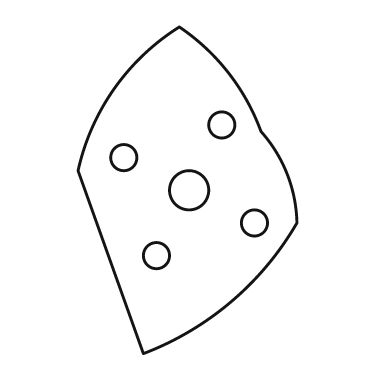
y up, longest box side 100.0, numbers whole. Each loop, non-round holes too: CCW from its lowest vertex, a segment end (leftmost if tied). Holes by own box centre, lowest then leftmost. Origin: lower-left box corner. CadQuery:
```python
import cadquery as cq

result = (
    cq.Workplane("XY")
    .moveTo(20.0, 0.0)
    .threePointArc((47.0, 16.0), (67.0, 40.0))
    .threePointArc((64.0, 55.0), (56.0, 68.0))
    .threePointArc((46.0, 86.0), (31.0, 100.0))
    .threePointArc((11.0, 81.0), (0.0, 56.0))
    .close()
    .moveTo(24.0, 30.0)
    .circle(4.0)
    .moveTo(54.0, 40.0)
    .circle(4.0)
    .moveTo(34.0, 50.0)
    .circle(6.0)
    .moveTo(14.0, 60.0)
    .circle(4.0)
    .moveTo(44.0, 70.0)
    .circle(4.0)
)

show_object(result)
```